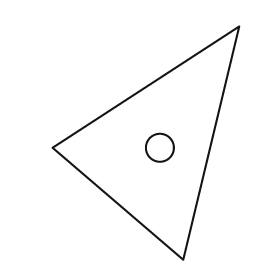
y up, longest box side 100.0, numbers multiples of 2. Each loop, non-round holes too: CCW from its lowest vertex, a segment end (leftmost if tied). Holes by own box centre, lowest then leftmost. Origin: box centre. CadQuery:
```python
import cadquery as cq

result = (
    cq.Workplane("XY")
    .moveTo(16.0, -50.0)
    .lineTo(40.0, 50.0)
    .lineTo(-40.0, -2.0)
    .close()
    .moveTo(6.0, -2.0)
    .circle(6.0)
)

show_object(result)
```